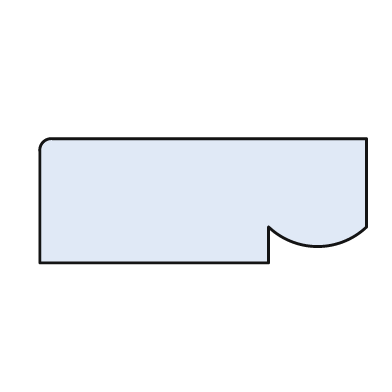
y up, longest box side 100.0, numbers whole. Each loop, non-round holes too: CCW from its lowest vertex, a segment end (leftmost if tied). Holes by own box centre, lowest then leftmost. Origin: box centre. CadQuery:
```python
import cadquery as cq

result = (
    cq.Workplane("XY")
    .moveTo(-50.0, -19.0)
    .lineTo(20.0, -19.0)
    .lineTo(20.0, -8.0)
    .threePointArc((35.0, -14.0), (50.0, -8.0))
    .lineTo(50.0, 19.0)
    .lineTo(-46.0, 19.0)
    .threePointArc((-49.0, 18.0), (-50.0, 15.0))
    .close()
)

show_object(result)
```